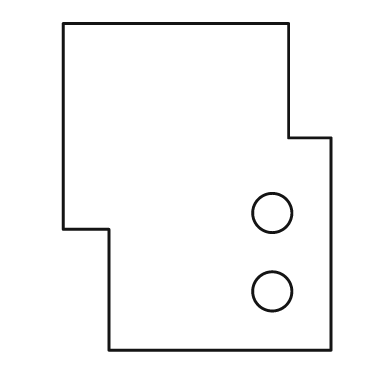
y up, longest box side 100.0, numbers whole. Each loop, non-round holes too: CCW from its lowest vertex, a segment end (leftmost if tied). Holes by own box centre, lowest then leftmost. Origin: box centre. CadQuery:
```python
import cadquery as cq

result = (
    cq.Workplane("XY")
    .moveTo(-27.0, -50.0)
    .lineTo(41.0, -50.0)
    .lineTo(41.0, 15.0)
    .lineTo(28.0, 15.0)
    .lineTo(28.0, 50.0)
    .lineTo(-41.0, 50.0)
    .lineTo(-41.0, -13.0)
    .lineTo(-27.0, -13.0)
    .close()
    .moveTo(23.0, -32.0)
    .circle(6.0)
    .moveTo(23.0, -8.0)
    .circle(6.0)
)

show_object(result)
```